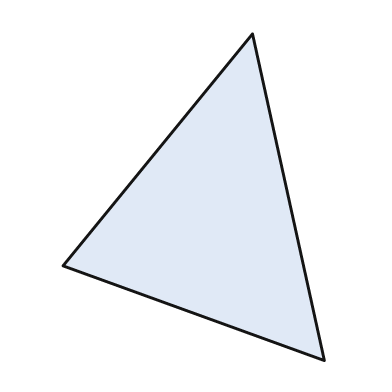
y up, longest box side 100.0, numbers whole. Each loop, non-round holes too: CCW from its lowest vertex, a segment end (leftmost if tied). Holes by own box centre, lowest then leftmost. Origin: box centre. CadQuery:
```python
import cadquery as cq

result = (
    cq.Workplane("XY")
    .moveTo(40.0, -50.0)
    .lineTo(18.0, 50.0)
    .lineTo(-40.0, -21.0)
    .close()
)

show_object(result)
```